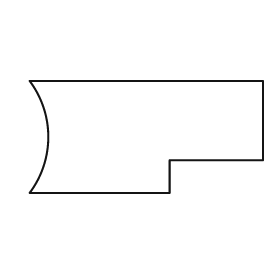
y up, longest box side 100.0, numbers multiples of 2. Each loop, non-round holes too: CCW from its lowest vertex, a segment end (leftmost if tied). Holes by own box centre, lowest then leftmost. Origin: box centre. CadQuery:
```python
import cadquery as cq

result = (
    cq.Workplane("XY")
    .moveTo(-50.0, -24.0)
    .lineTo(10.0, -24.0)
    .lineTo(10.0, -10.0)
    .lineTo(50.0, -10.0)
    .lineTo(50.0, 24.0)
    .lineTo(-50.0, 24.0)
    .threePointArc((-42.0, 0.0), (-50.0, -24.0))
    .close()
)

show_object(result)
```